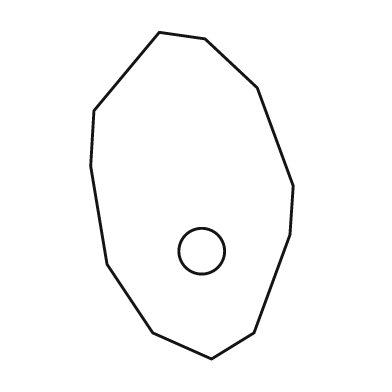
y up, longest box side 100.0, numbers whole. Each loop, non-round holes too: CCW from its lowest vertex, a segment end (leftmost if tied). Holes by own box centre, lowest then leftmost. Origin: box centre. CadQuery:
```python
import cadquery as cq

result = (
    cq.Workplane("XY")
    .moveTo(6.0, -50.0)
    .lineTo(19.0, -42.0)
    .lineTo(30.0, -12.0)
    .lineTo(31.0, 3.0)
    .lineTo(20.0, 33.0)
    .lineTo(4.0, 48.0)
    .lineTo(-10.0, 50.0)
    .lineTo(-30.0, 26.0)
    .lineTo(-31.0, 9.0)
    .lineTo(-26.0, -21.0)
    .lineTo(-12.0, -42.0)
    .close()
    .moveTo(3.0, -17.0)
    .circle(7.0)
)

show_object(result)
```